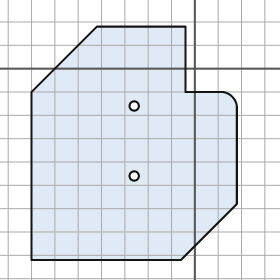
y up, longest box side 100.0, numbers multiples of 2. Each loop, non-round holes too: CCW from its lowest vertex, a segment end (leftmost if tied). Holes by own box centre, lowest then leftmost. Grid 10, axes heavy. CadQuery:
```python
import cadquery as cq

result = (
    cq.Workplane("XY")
    .moveTo(-70.0, -82.0)
    .lineTo(-6.0, -82.0)
    .lineTo(18.0, -58.0)
    .lineTo(18.0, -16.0)
    .threePointArc((16.0, -12.0), (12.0, -10.0))
    .lineTo(-4.0, -10.0)
    .lineTo(-4.0, 18.0)
    .lineTo(-42.0, 18.0)
    .lineTo(-70.0, -10.0)
    .close()
    .moveTo(-26.0, -46.0)
    .circle(2.0)
    .moveTo(-26.0, -16.0)
    .circle(2.0)
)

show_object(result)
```